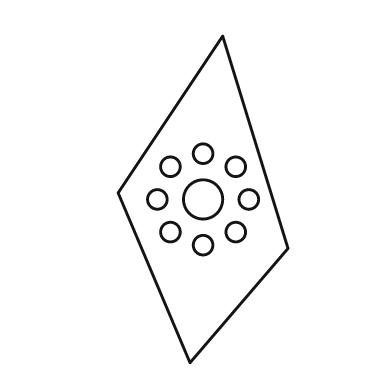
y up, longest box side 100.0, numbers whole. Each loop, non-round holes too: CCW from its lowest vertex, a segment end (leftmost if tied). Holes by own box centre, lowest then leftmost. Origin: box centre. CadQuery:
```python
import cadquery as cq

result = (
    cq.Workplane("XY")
    .moveTo(-4.0, -50.0)
    .lineTo(26.0, -15.0)
    .lineTo(6.0, 50.0)
    .lineTo(-26.0, 2.0)
    .close()
    .moveTo(0.0, -14.0)
    .circle(3.0)
    .moveTo(-10.0, -10.0)
    .circle(3.0)
    .moveTo(10.0, -10.0)
    .circle(3.0)
    .moveTo(-14.0, 0.0)
    .circle(3.0)
    .moveTo(0.0, 0.0)
    .circle(6.0)
    .moveTo(14.0, 0.0)
    .circle(3.0)
    .moveTo(-10.0, 10.0)
    .circle(3.0)
    .moveTo(10.0, 10.0)
    .circle(3.0)
    .moveTo(0.0, 14.0)
    .circle(3.0)
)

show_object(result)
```